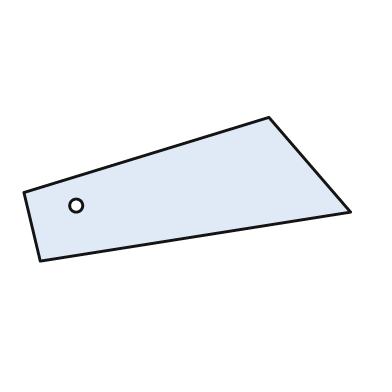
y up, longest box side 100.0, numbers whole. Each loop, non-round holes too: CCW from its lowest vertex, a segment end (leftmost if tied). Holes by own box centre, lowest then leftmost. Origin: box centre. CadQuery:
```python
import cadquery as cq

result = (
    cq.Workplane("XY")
    .moveTo(-45.0, -22.0)
    .lineTo(50.0, -7.0)
    .lineTo(25.0, 22.0)
    .lineTo(-50.0, -1.0)
    .close()
    .moveTo(-34.0, -5.0)
    .circle(2.0)
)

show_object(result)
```